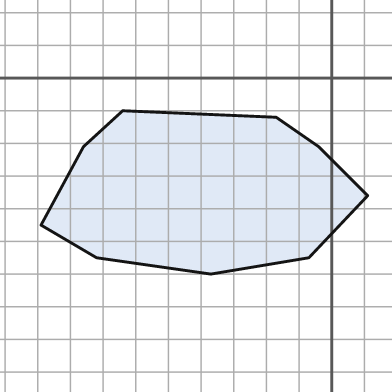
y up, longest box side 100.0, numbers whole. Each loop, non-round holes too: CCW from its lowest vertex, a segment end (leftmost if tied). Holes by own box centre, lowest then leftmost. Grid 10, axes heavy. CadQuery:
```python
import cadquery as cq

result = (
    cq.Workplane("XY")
    .moveTo(-37.0, -60.0)
    .lineTo(-7.0, -55.0)
    .lineTo(11.0, -36.0)
    .lineTo(-4.0, -21.0)
    .lineTo(-17.0, -12.0)
    .lineTo(-64.0, -10.0)
    .lineTo(-76.0, -21.0)
    .lineTo(-89.0, -45.0)
    .lineTo(-72.0, -55.0)
    .close()
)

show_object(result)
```